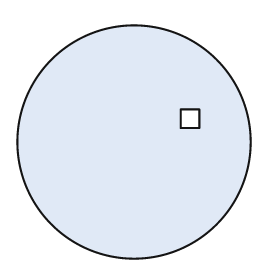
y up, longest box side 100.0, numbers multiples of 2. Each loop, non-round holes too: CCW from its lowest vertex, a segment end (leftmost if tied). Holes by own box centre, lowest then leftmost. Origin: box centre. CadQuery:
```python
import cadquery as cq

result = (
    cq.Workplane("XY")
    .moveTo(0.0, 0.0)
    .circle(50.0)
    .moveTo(20.0, 6.0)
    .lineTo(28.0, 6.0)
    .lineTo(28.0, 14.0)
    .lineTo(20.0, 14.0)
    .close()
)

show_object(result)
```